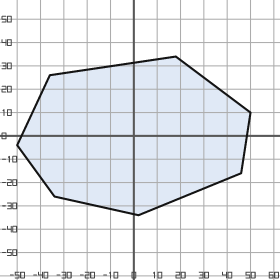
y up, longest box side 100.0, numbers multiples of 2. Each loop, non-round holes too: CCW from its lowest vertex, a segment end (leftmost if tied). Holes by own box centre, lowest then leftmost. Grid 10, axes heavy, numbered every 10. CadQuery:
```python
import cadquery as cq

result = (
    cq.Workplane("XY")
    .moveTo(2.0, -34.0)
    .lineTo(46.0, -16.0)
    .lineTo(50.0, 10.0)
    .lineTo(18.0, 34.0)
    .lineTo(-36.0, 26.0)
    .lineTo(-50.0, -4.0)
    .lineTo(-34.0, -26.0)
    .close()
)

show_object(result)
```